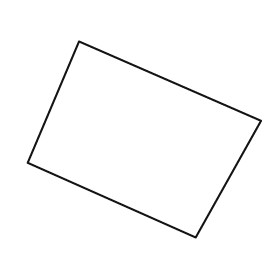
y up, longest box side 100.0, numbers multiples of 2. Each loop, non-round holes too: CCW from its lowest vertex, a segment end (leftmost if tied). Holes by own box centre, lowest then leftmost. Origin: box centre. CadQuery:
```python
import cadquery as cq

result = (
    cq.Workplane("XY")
    .moveTo(22.0, -42.0)
    .lineTo(50.0, 8.0)
    .lineTo(-28.0, 42.0)
    .lineTo(-50.0, -10.0)
    .close()
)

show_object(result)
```